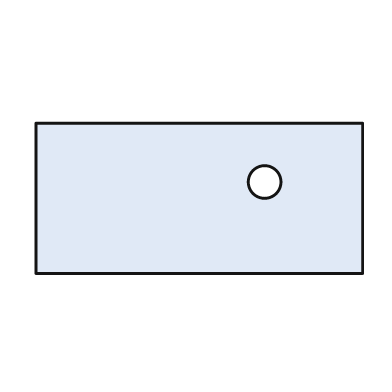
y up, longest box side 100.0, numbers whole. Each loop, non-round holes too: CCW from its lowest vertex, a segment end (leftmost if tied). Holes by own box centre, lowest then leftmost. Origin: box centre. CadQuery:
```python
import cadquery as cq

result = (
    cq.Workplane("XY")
    .moveTo(-50.0, -23.0)
    .lineTo(50.0, -23.0)
    .lineTo(50.0, 23.0)
    .lineTo(-50.0, 23.0)
    .close()
    .moveTo(20.0, 5.0)
    .circle(5.0)
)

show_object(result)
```